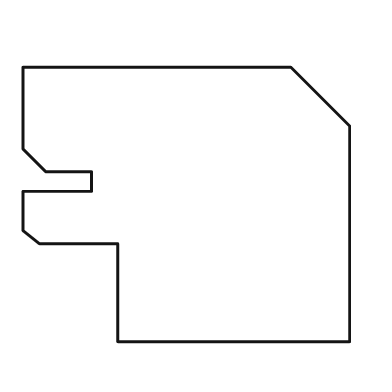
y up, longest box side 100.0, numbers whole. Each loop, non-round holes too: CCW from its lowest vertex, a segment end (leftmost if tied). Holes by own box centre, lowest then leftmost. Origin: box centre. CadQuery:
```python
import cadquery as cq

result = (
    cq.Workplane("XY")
    .moveTo(-21.0, -42.0)
    .lineTo(50.0, -42.0)
    .lineTo(50.0, 24.0)
    .lineTo(32.0, 42.0)
    .lineTo(-50.0, 42.0)
    .lineTo(-50.0, 17.0)
    .lineTo(-43.0, 10.0)
    .lineTo(-29.0, 10.0)
    .lineTo(-29.0, 4.0)
    .lineTo(-50.0, 4.0)
    .lineTo(-50.0, -8.0)
    .lineTo(-45.0, -12.0)
    .lineTo(-21.0, -12.0)
    .close()
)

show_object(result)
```